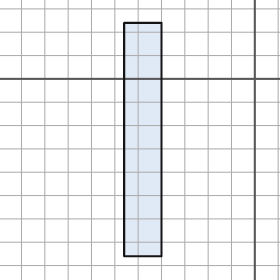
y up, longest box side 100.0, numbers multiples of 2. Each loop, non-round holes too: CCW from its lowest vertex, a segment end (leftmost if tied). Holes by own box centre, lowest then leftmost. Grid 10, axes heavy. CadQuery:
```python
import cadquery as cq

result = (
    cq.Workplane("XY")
    .moveTo(-56.0, -76.0)
    .lineTo(-40.0, -76.0)
    .lineTo(-40.0, 24.0)
    .lineTo(-56.0, 24.0)
    .close()
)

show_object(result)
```